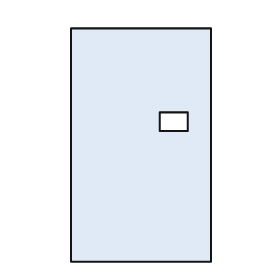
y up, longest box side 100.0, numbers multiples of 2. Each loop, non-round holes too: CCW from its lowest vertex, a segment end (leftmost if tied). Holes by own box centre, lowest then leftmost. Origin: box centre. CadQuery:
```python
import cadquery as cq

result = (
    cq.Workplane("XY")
    .moveTo(-30.0, -50.0)
    .lineTo(30.0, -50.0)
    .lineTo(30.0, 50.0)
    .lineTo(-30.0, 50.0)
    .close()
    .moveTo(8.0, 6.0)
    .lineTo(20.0, 6.0)
    .lineTo(20.0, 14.0)
    .lineTo(8.0, 14.0)
    .close()
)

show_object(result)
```